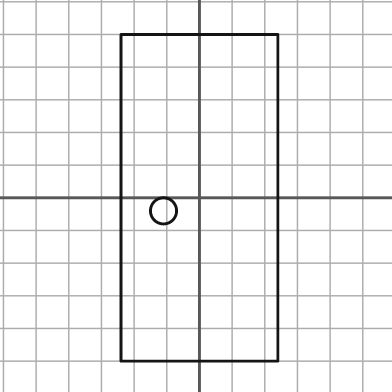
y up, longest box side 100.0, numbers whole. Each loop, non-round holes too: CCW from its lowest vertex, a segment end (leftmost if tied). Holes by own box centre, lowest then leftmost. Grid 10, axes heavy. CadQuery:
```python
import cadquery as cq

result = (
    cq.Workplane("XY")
    .moveTo(-24.0, -50.0)
    .lineTo(24.0, -50.0)
    .lineTo(24.0, 50.0)
    .lineTo(-24.0, 50.0)
    .close()
    .moveTo(-11.0, -4.0)
    .circle(4.0)
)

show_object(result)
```